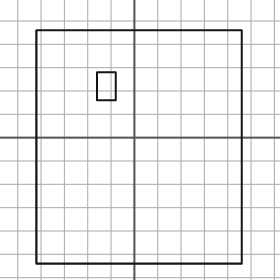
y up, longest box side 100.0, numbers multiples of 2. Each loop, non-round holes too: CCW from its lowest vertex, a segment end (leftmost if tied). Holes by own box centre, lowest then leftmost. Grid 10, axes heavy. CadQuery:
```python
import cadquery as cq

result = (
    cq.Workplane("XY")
    .moveTo(-42.0, -54.0)
    .lineTo(46.0, -54.0)
    .lineTo(46.0, 46.0)
    .lineTo(-42.0, 46.0)
    .close()
    .moveTo(-16.0, 16.0)
    .lineTo(-8.0, 16.0)
    .lineTo(-8.0, 28.0)
    .lineTo(-16.0, 28.0)
    .close()
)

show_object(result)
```